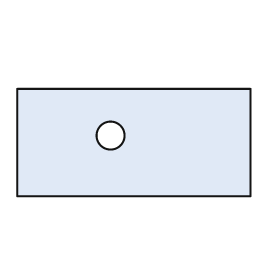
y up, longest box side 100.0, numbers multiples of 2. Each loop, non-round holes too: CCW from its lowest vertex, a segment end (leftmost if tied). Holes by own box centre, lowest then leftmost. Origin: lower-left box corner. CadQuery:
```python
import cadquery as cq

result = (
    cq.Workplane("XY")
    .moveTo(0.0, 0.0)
    .lineTo(100.0, 0.0)
    .lineTo(100.0, 46.0)
    .lineTo(0.0, 46.0)
    .close()
    .moveTo(40.0, 26.0)
    .circle(6.0)
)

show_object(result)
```